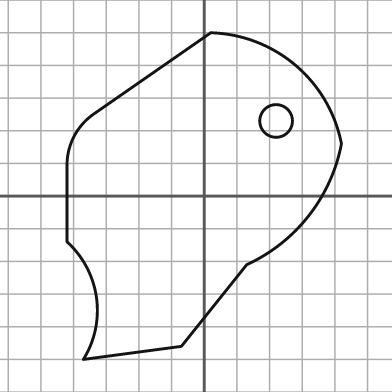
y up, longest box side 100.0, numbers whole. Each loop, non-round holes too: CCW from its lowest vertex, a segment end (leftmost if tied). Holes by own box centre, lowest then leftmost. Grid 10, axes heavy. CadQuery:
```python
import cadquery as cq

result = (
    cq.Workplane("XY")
    .moveTo(-37.0, -50.0)
    .lineTo(-7.0, -46.0)
    .lineTo(13.0, -21.0)
    .threePointArc((32.0, -6.0), (42.0, 16.0))
    .threePointArc((28.0, 40.0), (2.0, 50.0))
    .lineTo(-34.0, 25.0)
    .threePointArc((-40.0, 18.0), (-42.0, 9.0))
    .lineTo(-42.0, -14.0)
    .threePointArc((-33.0, -31.0), (-37.0, -50.0))
    .close()
    .moveTo(22.0, 23.0)
    .circle(5.0)
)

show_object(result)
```